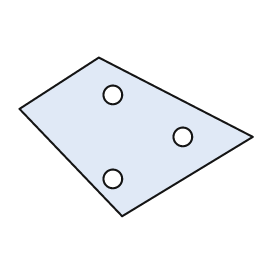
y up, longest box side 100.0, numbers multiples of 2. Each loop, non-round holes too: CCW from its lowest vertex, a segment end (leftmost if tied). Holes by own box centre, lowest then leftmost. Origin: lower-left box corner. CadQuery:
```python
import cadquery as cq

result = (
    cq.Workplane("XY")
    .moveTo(44.0, 0.0)
    .lineTo(100.0, 34.0)
    .lineTo(34.0, 68.0)
    .lineTo(0.0, 46.0)
    .close()
    .moveTo(40.0, 16.0)
    .circle(4.0)
    .moveTo(70.0, 34.0)
    .circle(4.0)
    .moveTo(40.0, 52.0)
    .circle(4.0)
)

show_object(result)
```